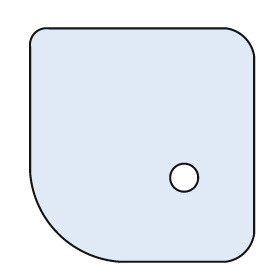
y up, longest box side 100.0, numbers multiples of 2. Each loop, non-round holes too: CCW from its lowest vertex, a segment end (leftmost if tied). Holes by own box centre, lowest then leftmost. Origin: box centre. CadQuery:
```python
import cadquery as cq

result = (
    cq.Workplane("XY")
    .moveTo(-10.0, -50.0)
    .lineTo(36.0, -50.0)
    .threePointArc((44.0, -46.0), (48.0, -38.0))
    .lineTo(48.0, 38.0)
    .threePointArc((44.0, 46.0), (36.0, 50.0))
    .lineTo(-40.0, 50.0)
    .threePointArc((-46.0, 48.0), (-48.0, 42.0))
    .lineTo(-48.0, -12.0)
    .threePointArc((-36.0, -38.0), (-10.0, -50.0))
    .close()
    .moveTo(18.0, -14.0)
    .circle(6.0)
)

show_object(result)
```